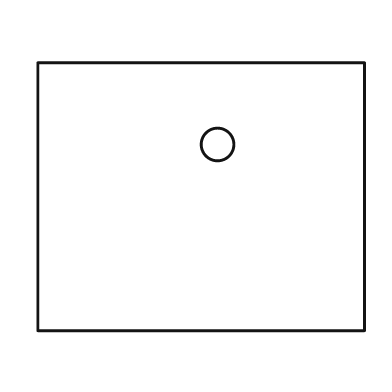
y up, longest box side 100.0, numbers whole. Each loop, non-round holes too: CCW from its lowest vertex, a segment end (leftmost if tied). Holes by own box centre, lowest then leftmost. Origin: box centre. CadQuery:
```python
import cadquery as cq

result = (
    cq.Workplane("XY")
    .moveTo(-50.0, -41.0)
    .lineTo(50.0, -41.0)
    .lineTo(50.0, 41.0)
    .lineTo(-50.0, 41.0)
    .close()
    .moveTo(5.0, 16.0)
    .circle(5.0)
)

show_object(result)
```